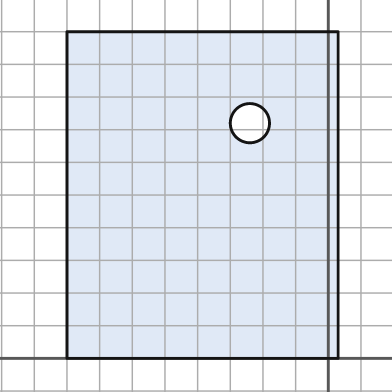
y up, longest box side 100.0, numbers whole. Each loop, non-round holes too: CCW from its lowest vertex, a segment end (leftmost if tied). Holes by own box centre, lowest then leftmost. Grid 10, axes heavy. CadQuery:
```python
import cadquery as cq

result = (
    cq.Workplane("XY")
    .moveTo(-80.0, 0.0)
    .lineTo(3.0, 0.0)
    .lineTo(3.0, 100.0)
    .lineTo(-80.0, 100.0)
    .close()
    .moveTo(-24.0, 72.0)
    .circle(6.0)
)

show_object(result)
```